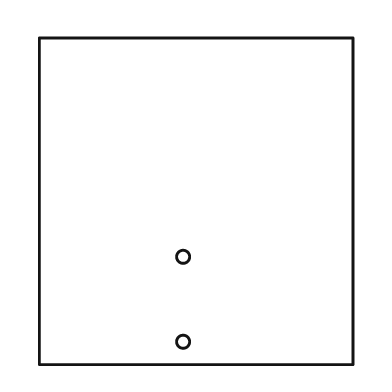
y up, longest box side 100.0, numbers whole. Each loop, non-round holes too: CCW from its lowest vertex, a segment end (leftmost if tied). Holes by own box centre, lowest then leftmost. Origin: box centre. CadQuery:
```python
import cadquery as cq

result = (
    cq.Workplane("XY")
    .moveTo(-48.0, -50.0)
    .lineTo(48.0, -50.0)
    .lineTo(48.0, 50.0)
    .lineTo(-48.0, 50.0)
    .close()
    .moveTo(-4.0, -43.0)
    .circle(2.0)
    .moveTo(-4.0, -17.0)
    .circle(2.0)
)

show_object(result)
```